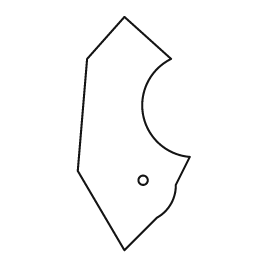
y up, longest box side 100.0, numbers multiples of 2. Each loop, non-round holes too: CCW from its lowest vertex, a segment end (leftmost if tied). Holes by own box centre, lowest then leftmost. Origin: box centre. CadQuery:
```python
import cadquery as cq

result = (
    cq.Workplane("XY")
    .moveTo(-4.0, -50.0)
    .lineTo(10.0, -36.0)
    .threePointArc((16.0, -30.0), (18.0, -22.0))
    .lineTo(24.0, -10.0)
    .threePointArc((4.0, 8.0), (16.0, 32.0))
    .lineTo(-4.0, 50.0)
    .lineTo(-20.0, 32.0)
    .lineTo(-24.0, -16.0)
    .close()
    .moveTo(4.0, -20.0)
    .circle(2.0)
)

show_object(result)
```